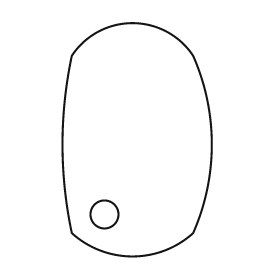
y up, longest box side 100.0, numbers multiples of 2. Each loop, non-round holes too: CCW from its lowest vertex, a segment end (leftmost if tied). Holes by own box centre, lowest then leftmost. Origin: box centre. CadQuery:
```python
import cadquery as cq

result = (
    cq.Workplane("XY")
    .moveTo(-28.0, -40.0)
    .threePointArc((-2.0, -50.0), (24.0, -40.0))
    .threePointArc((32.0, -2.0), (24.0, 36.0))
    .threePointArc((-2.0, 50.0), (-28.0, 36.0))
    .threePointArc((-32.0, -2.0), (-28.0, -40.0))
    .close()
    .moveTo(-14.0, -32.0)
    .circle(6.0)
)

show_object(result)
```